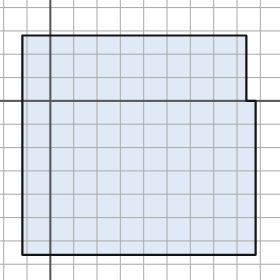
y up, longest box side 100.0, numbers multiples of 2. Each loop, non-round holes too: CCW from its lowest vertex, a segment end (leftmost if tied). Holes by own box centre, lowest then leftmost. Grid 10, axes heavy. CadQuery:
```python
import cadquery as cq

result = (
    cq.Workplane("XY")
    .moveTo(-12.0, -66.0)
    .lineTo(88.0, -66.0)
    .lineTo(88.0, 0.0)
    .lineTo(84.0, 0.0)
    .lineTo(84.0, 28.0)
    .lineTo(-12.0, 28.0)
    .close()
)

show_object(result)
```